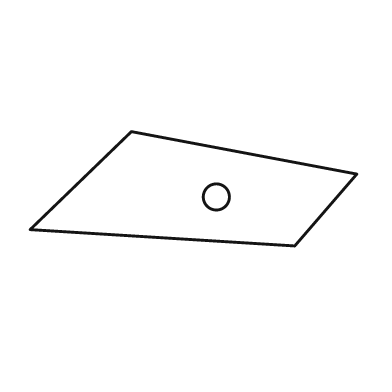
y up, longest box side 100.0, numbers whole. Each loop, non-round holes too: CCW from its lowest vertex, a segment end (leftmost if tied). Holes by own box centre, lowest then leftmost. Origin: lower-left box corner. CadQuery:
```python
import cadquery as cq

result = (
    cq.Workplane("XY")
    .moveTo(81.0, 0.0)
    .lineTo(100.0, 22.0)
    .lineTo(31.0, 35.0)
    .lineTo(0.0, 5.0)
    .close()
    .moveTo(57.0, 15.0)
    .circle(4.0)
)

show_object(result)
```